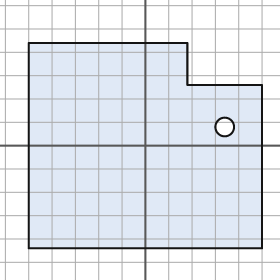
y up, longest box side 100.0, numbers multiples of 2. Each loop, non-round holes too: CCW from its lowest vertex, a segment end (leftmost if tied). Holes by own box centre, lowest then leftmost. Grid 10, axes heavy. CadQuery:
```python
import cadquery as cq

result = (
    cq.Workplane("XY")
    .moveTo(-50.0, -44.0)
    .lineTo(50.0, -44.0)
    .lineTo(50.0, 26.0)
    .lineTo(18.0, 26.0)
    .lineTo(18.0, 44.0)
    .lineTo(-50.0, 44.0)
    .close()
    .moveTo(34.0, 8.0)
    .circle(4.0)
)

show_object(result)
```